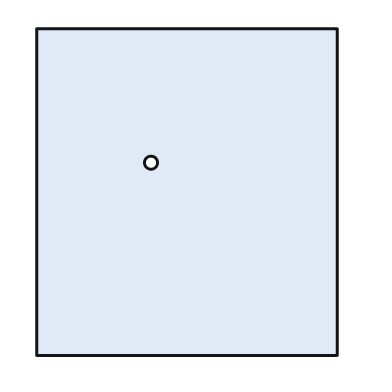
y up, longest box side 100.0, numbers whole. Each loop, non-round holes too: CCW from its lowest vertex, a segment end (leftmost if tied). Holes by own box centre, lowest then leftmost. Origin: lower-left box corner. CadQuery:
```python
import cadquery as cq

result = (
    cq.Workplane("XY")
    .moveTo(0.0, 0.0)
    .lineTo(92.0, 0.0)
    .lineTo(92.0, 100.0)
    .lineTo(0.0, 100.0)
    .close()
    .moveTo(35.0, 59.0)
    .circle(2.0)
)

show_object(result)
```